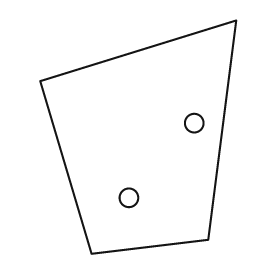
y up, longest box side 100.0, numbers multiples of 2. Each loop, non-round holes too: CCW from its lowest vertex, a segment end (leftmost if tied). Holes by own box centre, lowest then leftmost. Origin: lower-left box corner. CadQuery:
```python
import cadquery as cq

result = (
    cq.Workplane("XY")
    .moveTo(22.0, 0.0)
    .lineTo(72.0, 6.0)
    .lineTo(84.0, 100.0)
    .lineTo(0.0, 74.0)
    .close()
    .moveTo(38.0, 24.0)
    .circle(4.0)
    .moveTo(66.0, 56.0)
    .circle(4.0)
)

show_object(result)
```